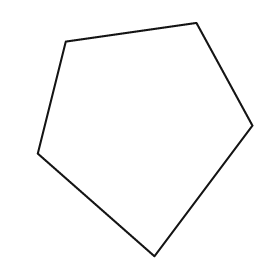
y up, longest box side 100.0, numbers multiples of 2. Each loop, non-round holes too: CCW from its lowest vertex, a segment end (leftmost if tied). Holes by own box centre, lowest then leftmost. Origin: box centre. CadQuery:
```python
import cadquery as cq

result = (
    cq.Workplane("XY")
    .moveTo(4.0, -50.0)
    .lineTo(46.0, 6.0)
    .lineTo(22.0, 50.0)
    .lineTo(-34.0, 42.0)
    .lineTo(-46.0, -6.0)
    .close()
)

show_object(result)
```